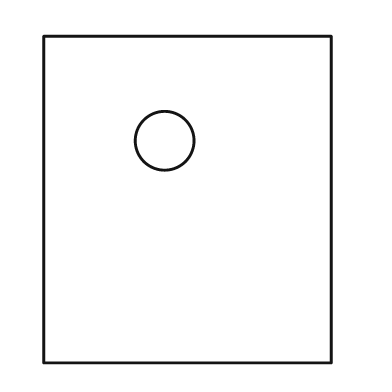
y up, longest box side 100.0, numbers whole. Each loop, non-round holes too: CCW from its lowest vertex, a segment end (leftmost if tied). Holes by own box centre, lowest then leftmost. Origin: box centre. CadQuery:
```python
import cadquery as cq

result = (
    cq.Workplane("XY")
    .moveTo(-44.0, -50.0)
    .lineTo(44.0, -50.0)
    .lineTo(44.0, 50.0)
    .lineTo(-44.0, 50.0)
    .close()
    .moveTo(-7.0, 18.0)
    .circle(9.0)
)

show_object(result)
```